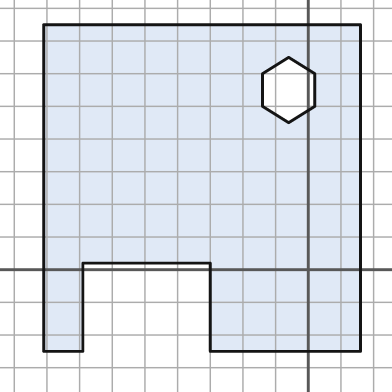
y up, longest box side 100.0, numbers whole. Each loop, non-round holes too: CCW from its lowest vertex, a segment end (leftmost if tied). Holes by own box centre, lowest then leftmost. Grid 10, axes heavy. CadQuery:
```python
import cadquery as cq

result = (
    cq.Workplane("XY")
    .moveTo(-81.0, -25.0)
    .lineTo(-69.0, -25.0)
    .lineTo(-69.0, 2.0)
    .lineTo(-30.0, 2.0)
    .lineTo(-30.0, -25.0)
    .lineTo(16.0, -25.0)
    .lineTo(16.0, 75.0)
    .lineTo(-81.0, 75.0)
    .close()
    .moveTo(-6.0, 45.0)
    .lineTo(2.0, 50.0)
    .lineTo(2.0, 60.0)
    .lineTo(-6.0, 65.0)
    .lineTo(-14.0, 60.0)
    .lineTo(-14.0, 50.0)
    .close()
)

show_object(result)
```